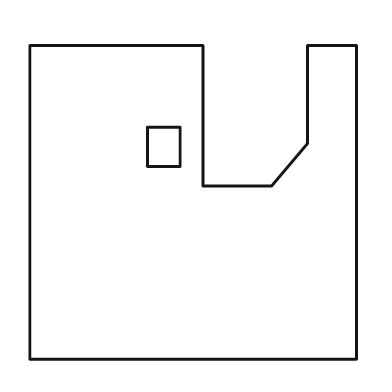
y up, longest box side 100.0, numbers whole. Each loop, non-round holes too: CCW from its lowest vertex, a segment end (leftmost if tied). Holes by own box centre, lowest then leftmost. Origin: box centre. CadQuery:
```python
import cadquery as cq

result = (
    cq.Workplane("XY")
    .moveTo(-50.0, -48.0)
    .lineTo(50.0, -48.0)
    .lineTo(50.0, 48.0)
    .lineTo(35.0, 48.0)
    .lineTo(35.0, 18.0)
    .lineTo(24.0, 5.0)
    .lineTo(3.0, 5.0)
    .lineTo(3.0, 48.0)
    .lineTo(-50.0, 48.0)
    .close()
    .moveTo(-14.0, 11.0)
    .lineTo(-4.0, 11.0)
    .lineTo(-4.0, 23.0)
    .lineTo(-14.0, 23.0)
    .close()
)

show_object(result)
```